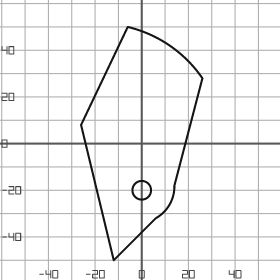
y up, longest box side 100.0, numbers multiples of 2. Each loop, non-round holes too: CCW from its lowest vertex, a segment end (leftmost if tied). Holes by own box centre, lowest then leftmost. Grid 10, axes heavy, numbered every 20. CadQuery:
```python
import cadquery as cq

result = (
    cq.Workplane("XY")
    .moveTo(-12.0, -50.0)
    .lineTo(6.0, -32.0)
    .threePointArc((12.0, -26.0), (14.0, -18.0))
    .lineTo(26.0, 28.0)
    .threePointArc((12.0, 42.0), (-6.0, 50.0))
    .lineTo(-26.0, 8.0)
    .close()
    .moveTo(0.0, -20.0)
    .circle(4.0)
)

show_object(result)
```